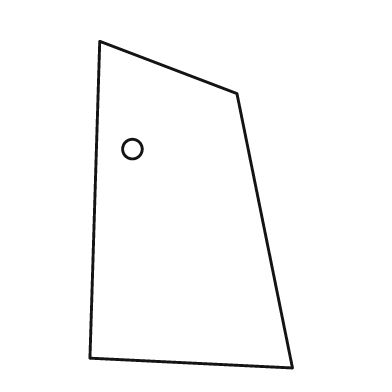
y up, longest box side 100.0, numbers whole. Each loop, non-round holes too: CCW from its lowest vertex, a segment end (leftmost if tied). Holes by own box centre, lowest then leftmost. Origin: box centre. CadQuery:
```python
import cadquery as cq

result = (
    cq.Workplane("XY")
    .moveTo(31.0, -50.0)
    .lineTo(14.0, 34.0)
    .lineTo(-28.0, 50.0)
    .lineTo(-31.0, -47.0)
    .close()
    .moveTo(-18.0, 17.0)
    .circle(3.0)
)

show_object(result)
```